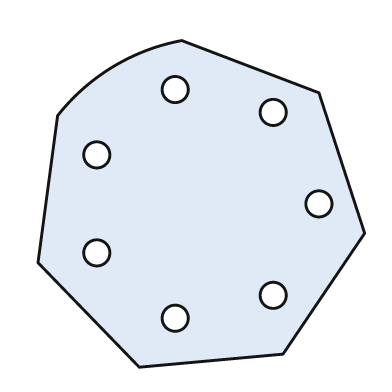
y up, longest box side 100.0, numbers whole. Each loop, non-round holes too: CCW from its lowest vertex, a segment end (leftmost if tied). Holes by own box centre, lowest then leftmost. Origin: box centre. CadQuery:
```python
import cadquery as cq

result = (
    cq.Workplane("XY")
    .moveTo(-19.0, -50.0)
    .lineTo(25.0, -46.0)
    .lineTo(50.0, -9.0)
    .lineTo(36.0, 34.0)
    .lineTo(-6.0, 50.0)
    .threePointArc((-27.0, 42.0), (-44.0, 27.0))
    .lineTo(-50.0, -18.0)
    .close()
    .moveTo(-8.0, -35.0)
    .circle(4.0)
    .moveTo(22.0, -28.0)
    .circle(4.0)
    .moveTo(-32.0, -15.0)
    .circle(4.0)
    .moveTo(36.0, 0.0)
    .circle(4.0)
    .moveTo(-32.0, 15.0)
    .circle(4.0)
    .moveTo(22.0, 28.0)
    .circle(4.0)
    .moveTo(-8.0, 35.0)
    .circle(4.0)
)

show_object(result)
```